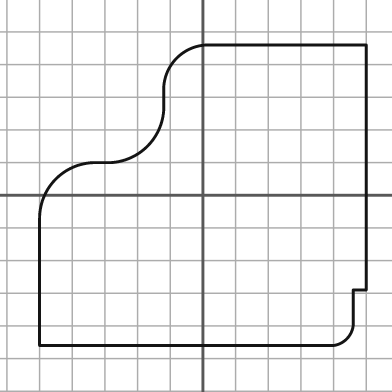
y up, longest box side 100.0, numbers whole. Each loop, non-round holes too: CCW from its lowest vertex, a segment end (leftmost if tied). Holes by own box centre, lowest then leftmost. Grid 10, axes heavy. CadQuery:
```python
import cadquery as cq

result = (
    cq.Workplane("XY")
    .moveTo(-50.0, -46.0)
    .lineTo(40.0, -46.0)
    .threePointArc((44.0, -44.0), (46.0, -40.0))
    .lineTo(46.0, -29.0)
    .lineTo(50.0, -29.0)
    .lineTo(50.0, 46.0)
    .lineTo(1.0, 46.0)
    .threePointArc((-8.0, 42.0), (-12.0, 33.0))
    .lineTo(-12.0, 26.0)
    .threePointArc((-17.0, 15.0), (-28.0, 10.0))
    .lineTo(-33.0, 10.0)
    .threePointArc((-45.0, 5.0), (-50.0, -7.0))
    .close()
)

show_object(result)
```